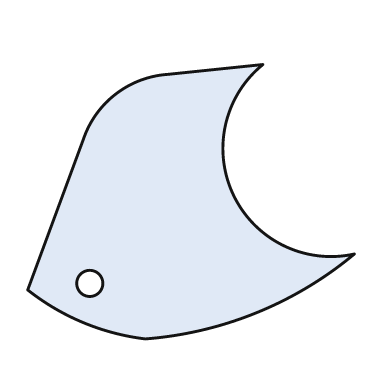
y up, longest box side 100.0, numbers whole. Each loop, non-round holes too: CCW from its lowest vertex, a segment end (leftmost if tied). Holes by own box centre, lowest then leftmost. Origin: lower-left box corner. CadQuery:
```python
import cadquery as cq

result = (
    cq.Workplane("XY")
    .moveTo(36.0, 0.0)
    .threePointArc((70.0, 8.0), (100.0, 26.0))
    .threePointArc((63.0, 44.0), (72.0, 84.0))
    .lineTo(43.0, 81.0)
    .threePointArc((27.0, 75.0), (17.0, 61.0))
    .lineTo(0.0, 15.0)
    .threePointArc((17.0, 5.0), (36.0, 0.0))
    .close()
    .moveTo(19.0, 17.0)
    .circle(4.0)
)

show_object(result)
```